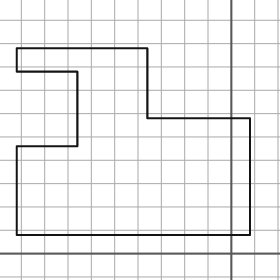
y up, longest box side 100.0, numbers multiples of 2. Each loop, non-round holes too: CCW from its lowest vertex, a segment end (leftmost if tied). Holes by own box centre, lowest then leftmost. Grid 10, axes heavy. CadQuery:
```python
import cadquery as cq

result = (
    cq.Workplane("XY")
    .moveTo(-92.0, 8.0)
    .lineTo(8.0, 8.0)
    .lineTo(8.0, 58.0)
    .lineTo(-36.0, 58.0)
    .lineTo(-36.0, 88.0)
    .lineTo(-92.0, 88.0)
    .lineTo(-92.0, 78.0)
    .lineTo(-66.0, 78.0)
    .lineTo(-66.0, 46.0)
    .lineTo(-92.0, 46.0)
    .close()
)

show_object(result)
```